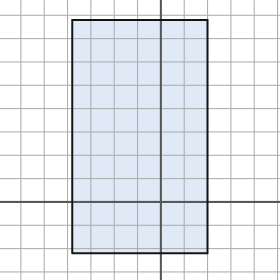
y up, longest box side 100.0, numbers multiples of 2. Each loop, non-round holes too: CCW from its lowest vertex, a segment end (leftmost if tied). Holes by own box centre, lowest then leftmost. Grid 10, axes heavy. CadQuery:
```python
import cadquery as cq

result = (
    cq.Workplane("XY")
    .moveTo(-38.0, -22.0)
    .lineTo(20.0, -22.0)
    .lineTo(20.0, 78.0)
    .lineTo(-38.0, 78.0)
    .close()
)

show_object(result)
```